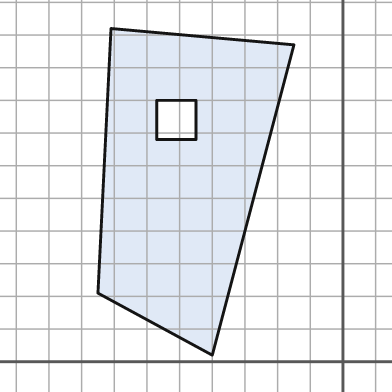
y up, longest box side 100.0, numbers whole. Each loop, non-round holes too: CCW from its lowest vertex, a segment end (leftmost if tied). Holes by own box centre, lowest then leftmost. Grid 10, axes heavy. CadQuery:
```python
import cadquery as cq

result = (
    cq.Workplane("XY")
    .moveTo(-40.0, 2.0)
    .lineTo(-15.0, 97.0)
    .lineTo(-71.0, 102.0)
    .lineTo(-75.0, 21.0)
    .close()
    .moveTo(-57.0, 68.0)
    .lineTo(-45.0, 68.0)
    .lineTo(-45.0, 80.0)
    .lineTo(-57.0, 80.0)
    .close()
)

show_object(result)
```